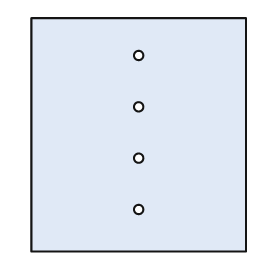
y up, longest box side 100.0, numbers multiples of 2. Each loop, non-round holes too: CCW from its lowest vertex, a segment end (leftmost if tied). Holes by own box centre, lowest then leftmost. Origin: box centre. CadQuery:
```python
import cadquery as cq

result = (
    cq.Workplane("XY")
    .moveTo(-46.0, -50.0)
    .lineTo(46.0, -50.0)
    .lineTo(46.0, 50.0)
    .lineTo(-46.0, 50.0)
    .close()
    .moveTo(0.0, -32.0)
    .circle(2.0)
    .moveTo(0.0, -10.0)
    .circle(2.0)
    .moveTo(0.0, 12.0)
    .circle(2.0)
    .moveTo(0.0, 34.0)
    .circle(2.0)
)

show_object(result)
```